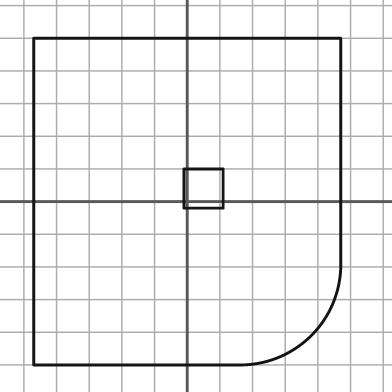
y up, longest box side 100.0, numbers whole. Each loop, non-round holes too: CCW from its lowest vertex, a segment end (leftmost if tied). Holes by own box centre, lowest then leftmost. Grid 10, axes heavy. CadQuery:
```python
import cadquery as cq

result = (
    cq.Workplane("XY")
    .moveTo(-47.0, -50.0)
    .lineTo(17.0, -50.0)
    .threePointArc((38.0, -41.0), (47.0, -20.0))
    .lineTo(47.0, 50.0)
    .lineTo(-47.0, 50.0)
    .close()
    .moveTo(-1.0, -2.0)
    .lineTo(11.0, -2.0)
    .lineTo(11.0, 10.0)
    .lineTo(-1.0, 10.0)
    .close()
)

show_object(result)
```